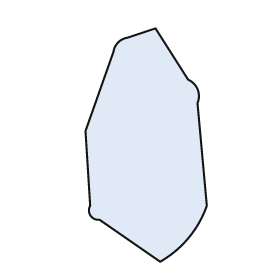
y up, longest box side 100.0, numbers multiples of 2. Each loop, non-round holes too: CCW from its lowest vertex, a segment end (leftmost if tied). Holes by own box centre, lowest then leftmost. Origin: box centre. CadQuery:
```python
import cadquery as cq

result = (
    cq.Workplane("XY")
    .moveTo(6.0, -50.0)
    .threePointArc((18.0, -40.0), (26.0, -26.0))
    .lineTo(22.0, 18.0)
    .threePointArc((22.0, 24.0), (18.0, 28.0))
    .lineTo(4.0, 50.0)
    .lineTo(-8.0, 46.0)
    .threePointArc((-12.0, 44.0), (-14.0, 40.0))
    .lineTo(-26.0, 6.0)
    .lineTo(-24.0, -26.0)
    .threePointArc((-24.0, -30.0), (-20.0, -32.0))
    .close()
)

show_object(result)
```